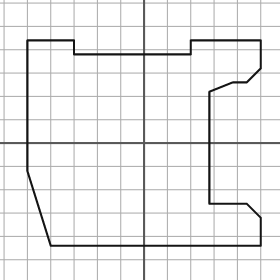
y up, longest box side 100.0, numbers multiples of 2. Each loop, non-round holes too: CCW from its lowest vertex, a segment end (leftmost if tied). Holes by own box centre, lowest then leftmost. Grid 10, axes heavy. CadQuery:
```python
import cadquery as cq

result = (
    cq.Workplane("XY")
    .moveTo(-40.0, -44.0)
    .lineTo(50.0, -44.0)
    .lineTo(50.0, -32.0)
    .lineTo(44.0, -26.0)
    .lineTo(28.0, -26.0)
    .lineTo(28.0, 22.0)
    .lineTo(38.0, 26.0)
    .lineTo(44.0, 26.0)
    .lineTo(50.0, 32.0)
    .lineTo(50.0, 44.0)
    .lineTo(20.0, 44.0)
    .lineTo(20.0, 38.0)
    .lineTo(-30.0, 38.0)
    .lineTo(-30.0, 44.0)
    .lineTo(-50.0, 44.0)
    .lineTo(-50.0, -12.0)
    .close()
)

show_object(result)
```